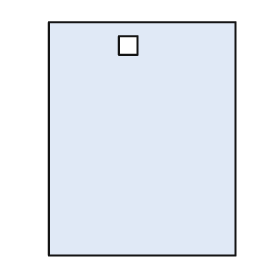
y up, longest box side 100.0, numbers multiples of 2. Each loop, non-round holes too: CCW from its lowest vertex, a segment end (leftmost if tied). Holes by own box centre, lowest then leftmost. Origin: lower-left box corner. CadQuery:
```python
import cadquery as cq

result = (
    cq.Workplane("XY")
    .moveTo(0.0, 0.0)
    .lineTo(80.0, 0.0)
    .lineTo(80.0, 100.0)
    .lineTo(0.0, 100.0)
    .close()
    .moveTo(30.0, 86.0)
    .lineTo(38.0, 86.0)
    .lineTo(38.0, 94.0)
    .lineTo(30.0, 94.0)
    .close()
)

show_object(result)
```